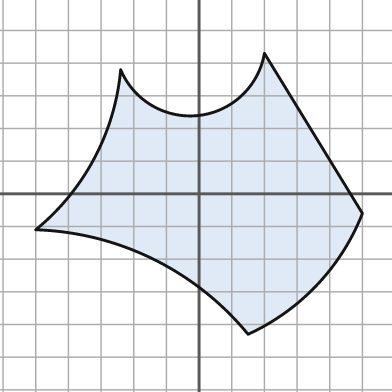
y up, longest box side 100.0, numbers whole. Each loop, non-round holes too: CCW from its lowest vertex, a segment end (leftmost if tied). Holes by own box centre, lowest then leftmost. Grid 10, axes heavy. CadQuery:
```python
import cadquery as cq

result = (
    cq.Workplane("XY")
    .moveTo(15.0, -43.0)
    .threePointArc((36.0, -28.0), (50.0, -6.0))
    .lineTo(20.0, 43.0)
    .threePointArc((0.0, 24.0), (-24.0, 38.0))
    .threePointArc((-32.0, 11.0), (-50.0, -11.0))
    .threePointArc((-14.0, -20.0), (15.0, -43.0))
    .close()
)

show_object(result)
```